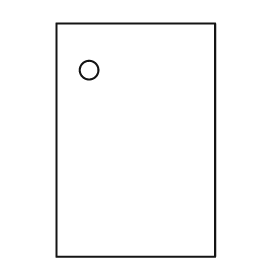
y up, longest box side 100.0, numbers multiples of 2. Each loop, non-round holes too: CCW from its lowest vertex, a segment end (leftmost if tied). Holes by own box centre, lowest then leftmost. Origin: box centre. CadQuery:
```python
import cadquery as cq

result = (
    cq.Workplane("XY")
    .moveTo(-34.0, -50.0)
    .lineTo(34.0, -50.0)
    .lineTo(34.0, 50.0)
    .lineTo(-34.0, 50.0)
    .close()
    .moveTo(-20.0, 30.0)
    .circle(4.0)
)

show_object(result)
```